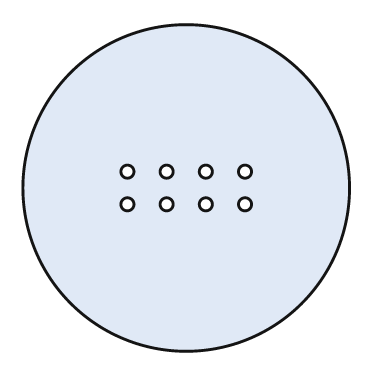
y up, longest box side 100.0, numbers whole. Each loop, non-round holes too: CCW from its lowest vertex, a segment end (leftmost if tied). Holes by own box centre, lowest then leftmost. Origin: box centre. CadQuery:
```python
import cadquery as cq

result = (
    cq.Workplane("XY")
    .moveTo(0.0, 0.0)
    .circle(50.0)
    .moveTo(-18.0, -5.0)
    .circle(2.0)
    .moveTo(-6.0, -5.0)
    .circle(2.0)
    .moveTo(6.0, -5.0)
    .circle(2.0)
    .moveTo(18.0, -5.0)
    .circle(2.0)
    .moveTo(-18.0, 5.0)
    .circle(2.0)
    .moveTo(-6.0, 5.0)
    .circle(2.0)
    .moveTo(6.0, 5.0)
    .circle(2.0)
    .moveTo(18.0, 5.0)
    .circle(2.0)
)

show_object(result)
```